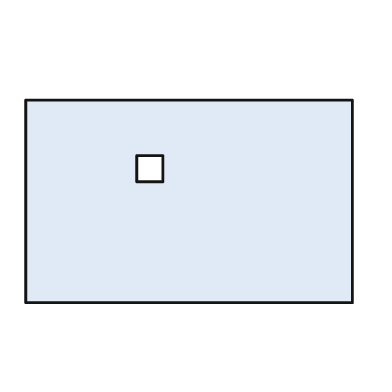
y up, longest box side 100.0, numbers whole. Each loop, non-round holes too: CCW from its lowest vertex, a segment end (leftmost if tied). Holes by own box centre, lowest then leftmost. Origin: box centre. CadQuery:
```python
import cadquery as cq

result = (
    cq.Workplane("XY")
    .moveTo(-50.0, -31.0)
    .lineTo(50.0, -31.0)
    .lineTo(50.0, 31.0)
    .lineTo(-50.0, 31.0)
    .close()
    .moveTo(-16.0, 6.0)
    .lineTo(-8.0, 6.0)
    .lineTo(-8.0, 14.0)
    .lineTo(-16.0, 14.0)
    .close()
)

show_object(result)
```